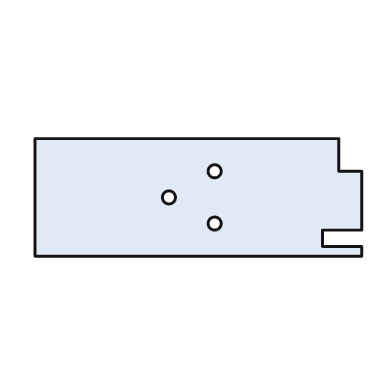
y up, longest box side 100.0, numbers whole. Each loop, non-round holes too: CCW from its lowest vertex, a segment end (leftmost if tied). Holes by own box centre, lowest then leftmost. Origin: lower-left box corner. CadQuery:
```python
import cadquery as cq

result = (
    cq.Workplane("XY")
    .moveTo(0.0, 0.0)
    .lineTo(100.0, 0.0)
    .lineTo(100.0, 3.0)
    .lineTo(88.0, 3.0)
    .lineTo(88.0, 8.0)
    .lineTo(100.0, 8.0)
    .lineTo(100.0, 26.0)
    .lineTo(93.0, 26.0)
    .lineTo(93.0, 36.0)
    .lineTo(0.0, 36.0)
    .close()
    .moveTo(55.0, 10.0)
    .circle(2.0)
    .moveTo(41.0, 18.0)
    .circle(2.0)
    .moveTo(55.0, 26.0)
    .circle(2.0)
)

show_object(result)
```